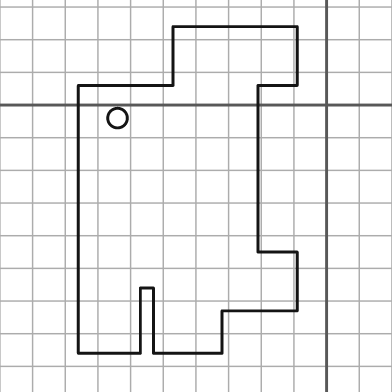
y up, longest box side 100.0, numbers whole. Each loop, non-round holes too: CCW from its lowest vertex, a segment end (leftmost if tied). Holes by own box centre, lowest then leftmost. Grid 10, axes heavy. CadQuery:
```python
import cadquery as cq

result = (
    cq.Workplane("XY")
    .moveTo(-76.0, -76.0)
    .lineTo(-57.0, -76.0)
    .lineTo(-57.0, -56.0)
    .lineTo(-53.0, -56.0)
    .lineTo(-53.0, -76.0)
    .lineTo(-32.0, -76.0)
    .lineTo(-32.0, -63.0)
    .lineTo(-9.0, -63.0)
    .lineTo(-9.0, -45.0)
    .lineTo(-21.0, -45.0)
    .lineTo(-21.0, 6.0)
    .lineTo(-9.0, 6.0)
    .lineTo(-9.0, 24.0)
    .lineTo(-47.0, 24.0)
    .lineTo(-47.0, 6.0)
    .lineTo(-76.0, 6.0)
    .close()
    .moveTo(-64.0, -4.0)
    .circle(3.0)
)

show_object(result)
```